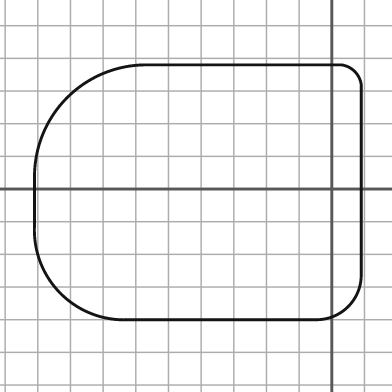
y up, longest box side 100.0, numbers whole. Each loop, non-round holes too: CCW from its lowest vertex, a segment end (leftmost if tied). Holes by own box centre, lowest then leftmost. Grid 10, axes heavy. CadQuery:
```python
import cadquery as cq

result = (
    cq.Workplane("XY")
    .moveTo(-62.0, -40.0)
    .lineTo(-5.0, -40.0)
    .threePointArc((5.0, -36.0), (9.0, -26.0))
    .lineTo(9.0, 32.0)
    .threePointArc((7.0, 36.0), (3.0, 38.0))
    .lineTo(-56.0, 38.0)
    .threePointArc((-81.0, 28.0), (-91.0, 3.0))
    .lineTo(-91.0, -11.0)
    .threePointArc((-83.0, -32.0), (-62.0, -40.0))
    .close()
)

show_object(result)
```